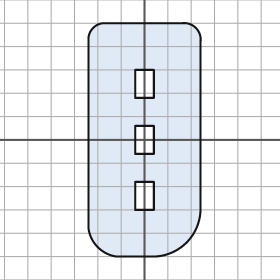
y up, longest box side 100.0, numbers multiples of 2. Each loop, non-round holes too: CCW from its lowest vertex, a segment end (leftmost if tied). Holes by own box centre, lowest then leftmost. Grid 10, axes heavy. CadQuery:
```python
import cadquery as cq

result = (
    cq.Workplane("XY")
    .moveTo(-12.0, -50.0)
    .lineTo(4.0, -50.0)
    .threePointArc((18.0, -44.0), (24.0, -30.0))
    .lineTo(24.0, 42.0)
    .threePointArc((22.0, 48.0), (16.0, 50.0))
    .lineTo(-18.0, 50.0)
    .threePointArc((-22.0, 48.0), (-24.0, 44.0))
    .lineTo(-24.0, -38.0)
    .threePointArc((-20.0, -46.0), (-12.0, -50.0))
    .close()
    .moveTo(-4.0, -30.0)
    .lineTo(4.0, -30.0)
    .lineTo(4.0, -18.0)
    .lineTo(-4.0, -18.0)
    .close()
    .moveTo(-4.0, -6.0)
    .lineTo(4.0, -6.0)
    .lineTo(4.0, 6.0)
    .lineTo(-4.0, 6.0)
    .close()
    .moveTo(-4.0, 18.0)
    .lineTo(4.0, 18.0)
    .lineTo(4.0, 30.0)
    .lineTo(-4.0, 30.0)
    .close()
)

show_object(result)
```